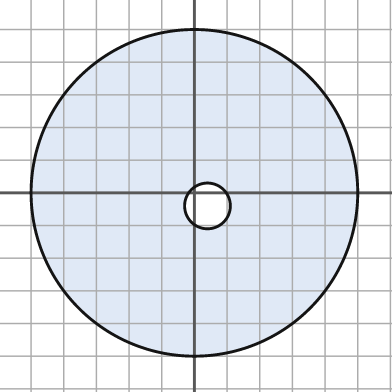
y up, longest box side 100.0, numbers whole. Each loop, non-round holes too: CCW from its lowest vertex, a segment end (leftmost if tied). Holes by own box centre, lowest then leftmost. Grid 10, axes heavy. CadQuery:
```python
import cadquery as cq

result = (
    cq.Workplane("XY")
    .moveTo(0.0, 0.0)
    .circle(50.0)
    .moveTo(4.0, -4.0)
    .circle(7.0)
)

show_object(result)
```